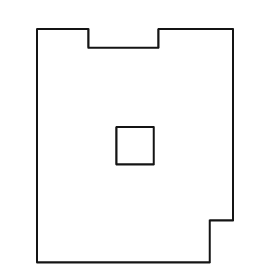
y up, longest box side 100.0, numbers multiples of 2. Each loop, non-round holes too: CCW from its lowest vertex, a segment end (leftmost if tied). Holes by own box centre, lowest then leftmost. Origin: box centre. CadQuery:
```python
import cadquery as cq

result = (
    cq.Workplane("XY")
    .moveTo(-42.0, -50.0)
    .lineTo(32.0, -50.0)
    .lineTo(32.0, -32.0)
    .lineTo(42.0, -32.0)
    .lineTo(42.0, 50.0)
    .lineTo(10.0, 50.0)
    .lineTo(10.0, 42.0)
    .lineTo(-20.0, 42.0)
    .lineTo(-20.0, 50.0)
    .lineTo(-42.0, 50.0)
    .close()
    .moveTo(-8.0, -8.0)
    .lineTo(8.0, -8.0)
    .lineTo(8.0, 8.0)
    .lineTo(-8.0, 8.0)
    .close()
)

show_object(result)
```